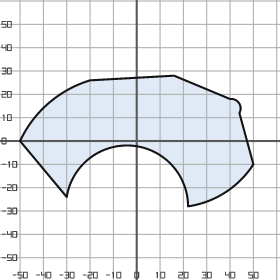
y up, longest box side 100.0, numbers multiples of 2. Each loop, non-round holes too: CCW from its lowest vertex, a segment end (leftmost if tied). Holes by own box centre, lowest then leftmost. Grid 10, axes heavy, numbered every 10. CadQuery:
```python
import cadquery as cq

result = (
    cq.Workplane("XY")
    .moveTo(22.0, -28.0)
    .threePointArc((38.0, -22.0), (50.0, -10.0))
    .lineTo(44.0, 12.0)
    .threePointArc((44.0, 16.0), (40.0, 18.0))
    .lineTo(16.0, 28.0)
    .lineTo(-20.0, 26.0)
    .threePointArc((-38.0, 16.0), (-50.0, 0.0))
    .lineTo(-30.0, -24.0)
    .threePointArc((-2.0, -2.0), (22.0, -28.0))
    .close()
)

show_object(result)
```